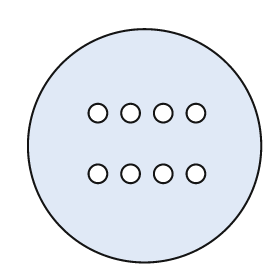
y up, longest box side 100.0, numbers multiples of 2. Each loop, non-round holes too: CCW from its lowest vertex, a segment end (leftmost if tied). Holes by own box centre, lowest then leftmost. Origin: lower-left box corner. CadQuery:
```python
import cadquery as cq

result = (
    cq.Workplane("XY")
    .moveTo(50.0, 50.0)
    .circle(50.0)
    .moveTo(30.0, 38.0)
    .circle(4.0)
    .moveTo(44.0, 38.0)
    .circle(4.0)
    .moveTo(58.0, 38.0)
    .circle(4.0)
    .moveTo(72.0, 38.0)
    .circle(4.0)
    .moveTo(30.0, 64.0)
    .circle(4.0)
    .moveTo(44.0, 64.0)
    .circle(4.0)
    .moveTo(58.0, 64.0)
    .circle(4.0)
    .moveTo(72.0, 64.0)
    .circle(4.0)
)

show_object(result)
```